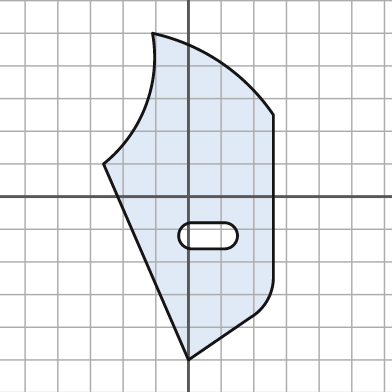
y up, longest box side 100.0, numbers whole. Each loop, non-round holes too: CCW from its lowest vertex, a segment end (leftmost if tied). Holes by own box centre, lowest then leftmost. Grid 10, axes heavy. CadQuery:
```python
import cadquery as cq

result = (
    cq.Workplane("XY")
    .moveTo(0.0, -50.0)
    .lineTo(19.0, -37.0)
    .threePointArc((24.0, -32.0), (26.0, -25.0))
    .lineTo(26.0, 25.0)
    .threePointArc((10.0, 41.0), (-11.0, 50.0))
    .threePointArc((-13.0, 28.0), (-26.0, 10.0))
    .close()
    .moveTo(1.0, -16.0)
    .lineTo(11.0, -16.0)
    .threePointArc((15.0, -12.0), (11.0, -8.0))
    .lineTo(1.0, -8.0)
    .threePointArc((-3.0, -12.0), (1.0, -16.0))
    .close()
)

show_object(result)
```